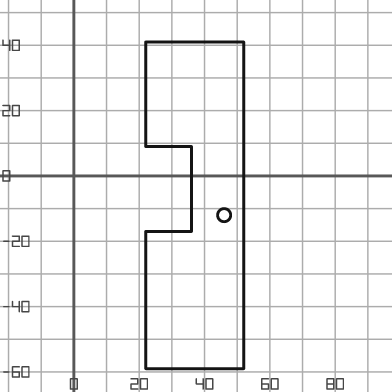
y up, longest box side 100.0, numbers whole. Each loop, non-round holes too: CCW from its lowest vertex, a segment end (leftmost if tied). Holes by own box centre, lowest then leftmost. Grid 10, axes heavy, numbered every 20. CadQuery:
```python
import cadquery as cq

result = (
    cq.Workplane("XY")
    .moveTo(22.0, -59.0)
    .lineTo(52.0, -59.0)
    .lineTo(52.0, 41.0)
    .lineTo(22.0, 41.0)
    .lineTo(22.0, 9.0)
    .lineTo(36.0, 9.0)
    .lineTo(36.0, -17.0)
    .lineTo(22.0, -17.0)
    .close()
    .moveTo(46.0, -12.0)
    .circle(2.0)
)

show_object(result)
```